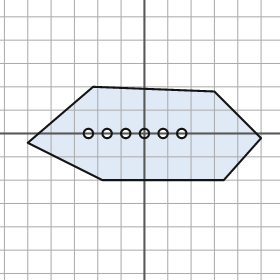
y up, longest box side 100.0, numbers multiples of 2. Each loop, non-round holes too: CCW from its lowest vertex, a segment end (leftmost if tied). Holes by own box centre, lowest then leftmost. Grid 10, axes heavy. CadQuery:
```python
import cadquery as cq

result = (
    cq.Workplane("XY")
    .moveTo(-18.0, -20.0)
    .lineTo(34.0, -20.0)
    .lineTo(50.0, -2.0)
    .lineTo(30.0, 18.0)
    .lineTo(-22.0, 20.0)
    .lineTo(-50.0, -4.0)
    .close()
    .moveTo(-24.0, 0.0)
    .circle(2.0)
    .moveTo(-16.0, 0.0)
    .circle(2.0)
    .moveTo(-8.0, 0.0)
    .circle(2.0)
    .moveTo(0.0, 0.0)
    .circle(2.0)
    .moveTo(8.0, 0.0)
    .circle(2.0)
    .moveTo(16.0, 0.0)
    .circle(2.0)
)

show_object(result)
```